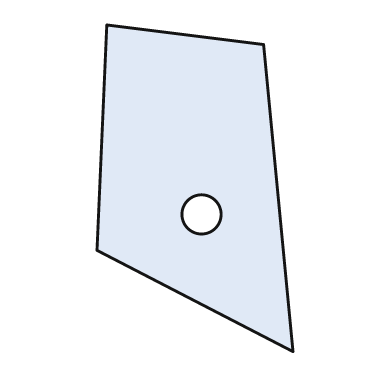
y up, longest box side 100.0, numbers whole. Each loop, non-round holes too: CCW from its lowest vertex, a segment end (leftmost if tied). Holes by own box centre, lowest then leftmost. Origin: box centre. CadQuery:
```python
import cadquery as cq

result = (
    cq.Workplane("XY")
    .moveTo(30.0, -50.0)
    .lineTo(21.0, 44.0)
    .lineTo(-27.0, 50.0)
    .lineTo(-30.0, -19.0)
    .close()
    .moveTo(2.0, -8.0)
    .circle(6.0)
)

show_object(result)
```